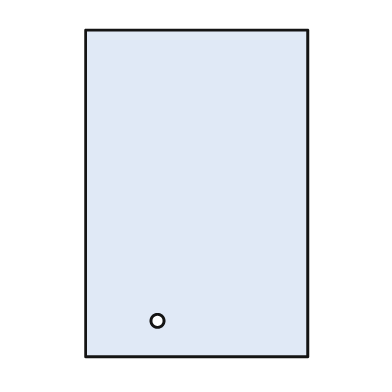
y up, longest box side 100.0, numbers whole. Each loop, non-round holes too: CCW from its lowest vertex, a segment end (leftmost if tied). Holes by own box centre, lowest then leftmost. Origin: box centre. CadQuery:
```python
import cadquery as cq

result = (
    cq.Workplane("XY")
    .moveTo(-34.0, -50.0)
    .lineTo(34.0, -50.0)
    .lineTo(34.0, 50.0)
    .lineTo(-34.0, 50.0)
    .close()
    .moveTo(-12.0, -39.0)
    .circle(2.0)
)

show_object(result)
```